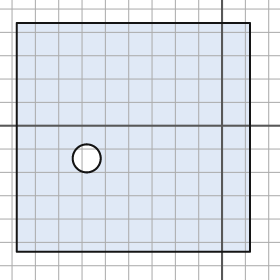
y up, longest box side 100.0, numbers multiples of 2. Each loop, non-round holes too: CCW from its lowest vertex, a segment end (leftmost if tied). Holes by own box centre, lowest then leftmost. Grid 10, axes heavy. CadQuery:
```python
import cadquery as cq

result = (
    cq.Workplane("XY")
    .moveTo(-88.0, -54.0)
    .lineTo(12.0, -54.0)
    .lineTo(12.0, 44.0)
    .lineTo(-88.0, 44.0)
    .close()
    .moveTo(-58.0, -14.0)
    .circle(6.0)
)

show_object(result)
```